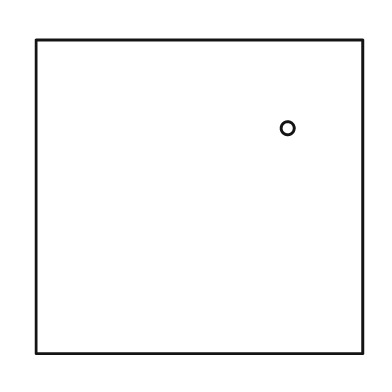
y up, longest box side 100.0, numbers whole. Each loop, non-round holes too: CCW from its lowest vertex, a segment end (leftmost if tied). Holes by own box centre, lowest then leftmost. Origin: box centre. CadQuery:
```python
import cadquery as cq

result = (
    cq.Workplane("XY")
    .moveTo(-50.0, -48.0)
    .lineTo(50.0, -48.0)
    .lineTo(50.0, 48.0)
    .lineTo(-50.0, 48.0)
    .close()
    .moveTo(27.0, 21.0)
    .circle(2.0)
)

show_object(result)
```